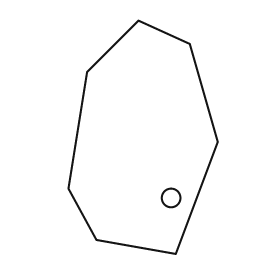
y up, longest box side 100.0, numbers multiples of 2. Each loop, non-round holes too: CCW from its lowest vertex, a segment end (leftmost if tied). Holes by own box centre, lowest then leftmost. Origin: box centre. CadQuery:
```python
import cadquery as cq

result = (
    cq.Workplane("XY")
    .moveTo(14.0, -50.0)
    .lineTo(32.0, -2.0)
    .lineTo(20.0, 40.0)
    .lineTo(-2.0, 50.0)
    .lineTo(-24.0, 28.0)
    .lineTo(-32.0, -22.0)
    .lineTo(-20.0, -44.0)
    .close()
    .moveTo(12.0, -26.0)
    .circle(4.0)
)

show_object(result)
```